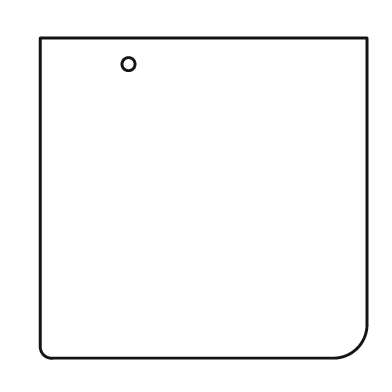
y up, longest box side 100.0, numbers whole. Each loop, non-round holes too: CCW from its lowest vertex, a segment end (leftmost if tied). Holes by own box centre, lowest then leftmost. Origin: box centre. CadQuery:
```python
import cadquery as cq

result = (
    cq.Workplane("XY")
    .moveTo(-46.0, -49.0)
    .lineTo(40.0, -49.0)
    .threePointArc((47.0, -46.0), (50.0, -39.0))
    .lineTo(50.0, 49.0)
    .lineTo(-50.0, 49.0)
    .lineTo(-50.0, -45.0)
    .threePointArc((-49.0, -48.0), (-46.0, -49.0))
    .close()
    .moveTo(-23.0, 41.0)
    .circle(2.0)
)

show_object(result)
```